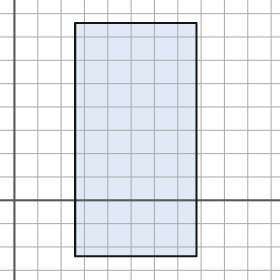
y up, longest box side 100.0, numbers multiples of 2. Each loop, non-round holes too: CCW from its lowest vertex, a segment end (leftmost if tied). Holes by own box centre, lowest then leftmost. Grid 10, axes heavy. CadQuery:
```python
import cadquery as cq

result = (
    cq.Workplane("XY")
    .moveTo(26.0, -24.0)
    .lineTo(78.0, -24.0)
    .lineTo(78.0, 76.0)
    .lineTo(26.0, 76.0)
    .close()
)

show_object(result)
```